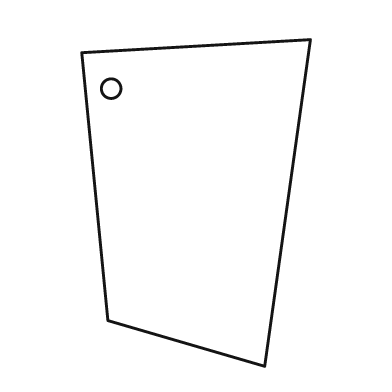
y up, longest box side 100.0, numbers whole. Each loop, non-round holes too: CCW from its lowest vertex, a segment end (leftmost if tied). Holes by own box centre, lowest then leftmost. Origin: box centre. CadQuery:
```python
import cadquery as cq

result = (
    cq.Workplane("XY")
    .moveTo(21.0, -50.0)
    .lineTo(35.0, 50.0)
    .lineTo(-35.0, 46.0)
    .lineTo(-27.0, -36.0)
    .close()
    .moveTo(-26.0, 35.0)
    .circle(3.0)
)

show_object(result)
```